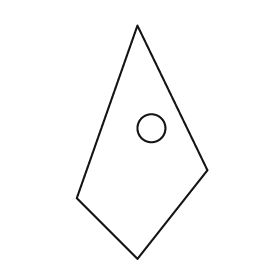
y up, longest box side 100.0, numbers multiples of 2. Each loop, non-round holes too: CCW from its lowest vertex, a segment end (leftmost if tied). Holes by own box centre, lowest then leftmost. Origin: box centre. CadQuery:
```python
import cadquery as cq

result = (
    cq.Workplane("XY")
    .moveTo(-2.0, -50.0)
    .lineTo(28.0, -12.0)
    .lineTo(-2.0, 50.0)
    .lineTo(-28.0, -24.0)
    .close()
    .moveTo(4.0, 6.0)
    .circle(6.0)
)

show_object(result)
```